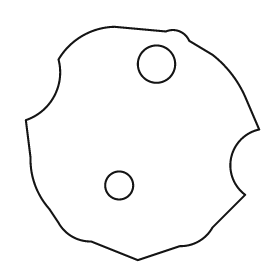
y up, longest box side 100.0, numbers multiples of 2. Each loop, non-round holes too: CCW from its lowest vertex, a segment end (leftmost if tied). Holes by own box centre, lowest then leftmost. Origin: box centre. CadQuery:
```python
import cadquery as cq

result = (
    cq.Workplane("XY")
    .moveTo(-2.0, -50.0)
    .lineTo(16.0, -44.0)
    .threePointArc((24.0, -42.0), (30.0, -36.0))
    .lineTo(44.0, -22.0)
    .threePointArc((38.0, -6.0), (50.0, 6.0))
    .lineTo(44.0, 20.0)
    .threePointArc((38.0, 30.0), (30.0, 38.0))
    .lineTo(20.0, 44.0)
    .threePointArc((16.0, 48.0), (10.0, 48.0))
    .lineTo(-12.0, 50.0)
    .threePointArc((-26.0, 46.0), (-36.0, 36.0))
    .threePointArc((-38.0, 20.0), (-50.0, 10.0))
    .lineTo(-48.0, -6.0)
    .threePointArc((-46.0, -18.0), (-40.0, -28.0))
    .lineTo(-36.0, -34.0)
    .threePointArc((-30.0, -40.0), (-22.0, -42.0))
    .close()
    .moveTo(-10.0, -18.0)
    .circle(6.0)
    .moveTo(6.0, 34.0)
    .circle(8.0)
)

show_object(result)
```